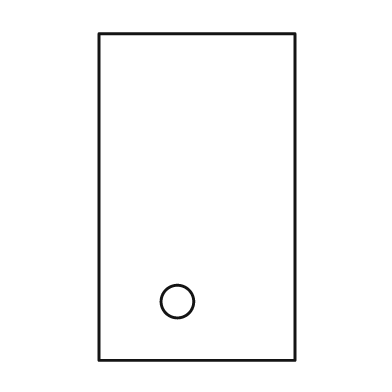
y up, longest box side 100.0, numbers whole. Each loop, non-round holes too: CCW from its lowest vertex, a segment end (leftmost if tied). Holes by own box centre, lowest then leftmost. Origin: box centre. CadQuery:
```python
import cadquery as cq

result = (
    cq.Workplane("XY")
    .moveTo(-30.0, -50.0)
    .lineTo(30.0, -50.0)
    .lineTo(30.0, 50.0)
    .lineTo(-30.0, 50.0)
    .close()
    .moveTo(-6.0, -32.0)
    .circle(5.0)
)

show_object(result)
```